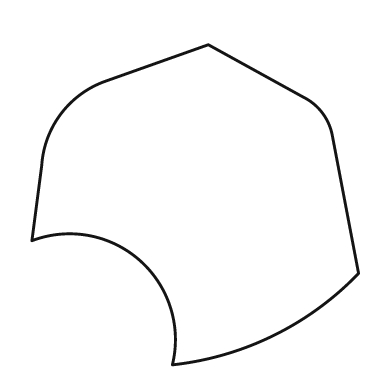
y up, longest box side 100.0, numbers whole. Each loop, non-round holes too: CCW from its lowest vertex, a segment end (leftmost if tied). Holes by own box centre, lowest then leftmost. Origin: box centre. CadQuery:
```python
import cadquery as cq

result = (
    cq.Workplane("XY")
    .moveTo(-7.0, -49.0)
    .threePointArc((24.0, -40.0), (50.0, -21.0))
    .lineTo(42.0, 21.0)
    .threePointArc((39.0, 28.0), (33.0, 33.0))
    .lineTo(4.0, 49.0)
    .lineTo(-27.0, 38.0)
    .threePointArc((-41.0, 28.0), (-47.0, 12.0))
    .lineTo(-50.0, -11.0)
    .threePointArc((-17.0, -17.0), (-7.0, -49.0))
    .close()
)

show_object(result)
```